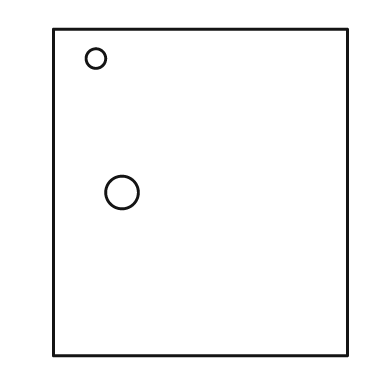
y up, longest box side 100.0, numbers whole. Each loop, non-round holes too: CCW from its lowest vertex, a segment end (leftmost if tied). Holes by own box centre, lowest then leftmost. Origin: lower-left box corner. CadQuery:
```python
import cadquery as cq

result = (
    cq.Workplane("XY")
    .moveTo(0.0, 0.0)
    .lineTo(90.0, 0.0)
    .lineTo(90.0, 100.0)
    .lineTo(0.0, 100.0)
    .close()
    .moveTo(21.0, 50.0)
    .circle(5.0)
    .moveTo(13.0, 91.0)
    .circle(3.0)
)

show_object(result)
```